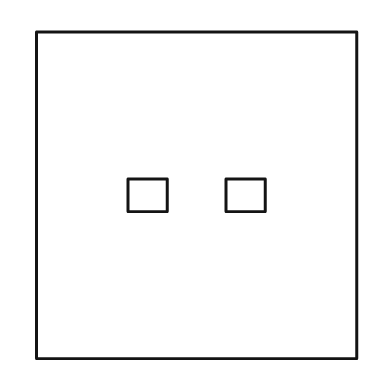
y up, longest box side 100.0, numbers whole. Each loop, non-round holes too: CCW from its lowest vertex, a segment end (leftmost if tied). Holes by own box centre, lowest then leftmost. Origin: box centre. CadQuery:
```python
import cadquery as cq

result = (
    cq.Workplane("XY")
    .moveTo(-49.0, -50.0)
    .lineTo(49.0, -50.0)
    .lineTo(49.0, 50.0)
    .lineTo(-49.0, 50.0)
    .close()
    .moveTo(-21.0, -5.0)
    .lineTo(-9.0, -5.0)
    .lineTo(-9.0, 5.0)
    .lineTo(-21.0, 5.0)
    .close()
    .moveTo(9.0, -5.0)
    .lineTo(21.0, -5.0)
    .lineTo(21.0, 5.0)
    .lineTo(9.0, 5.0)
    .close()
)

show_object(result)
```